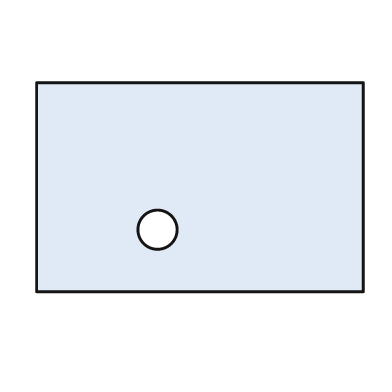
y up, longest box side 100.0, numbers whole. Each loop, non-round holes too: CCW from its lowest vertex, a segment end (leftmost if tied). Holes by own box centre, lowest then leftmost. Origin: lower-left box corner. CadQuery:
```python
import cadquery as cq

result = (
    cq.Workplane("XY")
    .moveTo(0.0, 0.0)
    .lineTo(100.0, 0.0)
    .lineTo(100.0, 64.0)
    .lineTo(0.0, 64.0)
    .close()
    .moveTo(37.0, 19.0)
    .circle(6.0)
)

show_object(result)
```